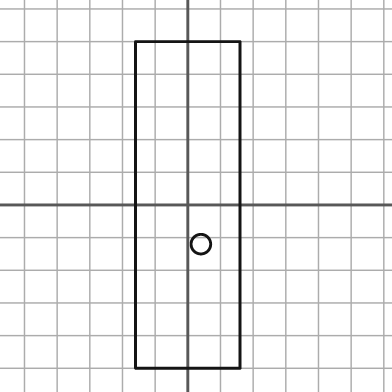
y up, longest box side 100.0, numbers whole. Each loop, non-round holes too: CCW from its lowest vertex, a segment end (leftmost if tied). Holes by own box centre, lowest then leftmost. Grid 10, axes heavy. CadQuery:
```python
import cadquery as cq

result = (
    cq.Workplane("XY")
    .moveTo(-16.0, -50.0)
    .lineTo(16.0, -50.0)
    .lineTo(16.0, 50.0)
    .lineTo(-16.0, 50.0)
    .close()
    .moveTo(4.0, -12.0)
    .circle(3.0)
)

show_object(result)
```